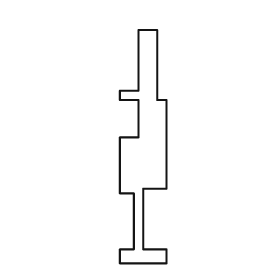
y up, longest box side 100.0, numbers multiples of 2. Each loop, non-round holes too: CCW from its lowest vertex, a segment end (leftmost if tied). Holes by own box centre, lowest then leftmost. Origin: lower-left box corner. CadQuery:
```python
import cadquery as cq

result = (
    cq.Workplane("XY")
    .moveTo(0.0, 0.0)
    .lineTo(20.0, 0.0)
    .lineTo(20.0, 6.0)
    .lineTo(10.0, 6.0)
    .lineTo(10.0, 32.0)
    .lineTo(20.0, 32.0)
    .lineTo(20.0, 70.0)
    .lineTo(16.0, 70.0)
    .lineTo(16.0, 100.0)
    .lineTo(8.0, 100.0)
    .lineTo(8.0, 74.0)
    .lineTo(0.0, 74.0)
    .lineTo(0.0, 70.0)
    .lineTo(8.0, 70.0)
    .lineTo(8.0, 54.0)
    .lineTo(0.0, 54.0)
    .lineTo(0.0, 30.0)
    .lineTo(6.0, 30.0)
    .lineTo(6.0, 6.0)
    .lineTo(0.0, 6.0)
    .close()
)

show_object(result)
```